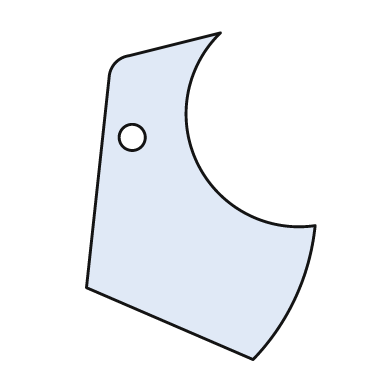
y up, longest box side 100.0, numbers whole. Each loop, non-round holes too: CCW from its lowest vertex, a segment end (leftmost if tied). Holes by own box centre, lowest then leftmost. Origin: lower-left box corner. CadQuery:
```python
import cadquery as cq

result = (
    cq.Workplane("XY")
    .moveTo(51.0, 0.0)
    .threePointArc((64.0, 19.0), (70.0, 41.0))
    .threePointArc((34.0, 60.0), (41.0, 100.0))
    .lineTo(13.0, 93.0)
    .threePointArc((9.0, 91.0), (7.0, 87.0))
    .lineTo(0.0, 22.0)
    .close()
    .moveTo(14.0, 68.0)
    .circle(4.0)
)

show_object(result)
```